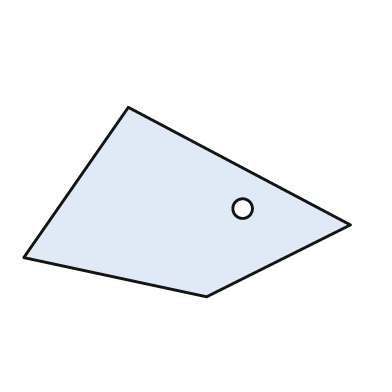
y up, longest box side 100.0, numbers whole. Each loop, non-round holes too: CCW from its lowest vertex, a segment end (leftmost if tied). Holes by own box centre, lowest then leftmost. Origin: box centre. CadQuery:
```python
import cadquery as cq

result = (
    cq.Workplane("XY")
    .moveTo(6.0, -29.0)
    .lineTo(50.0, -7.0)
    .lineTo(-18.0, 29.0)
    .lineTo(-50.0, -17.0)
    .close()
    .moveTo(17.0, -2.0)
    .circle(3.0)
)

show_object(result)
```